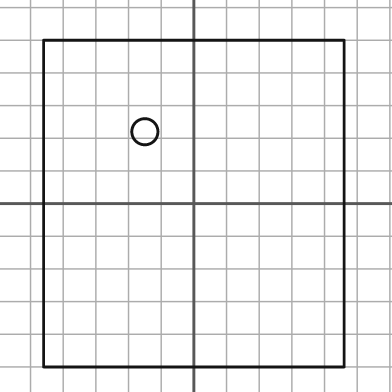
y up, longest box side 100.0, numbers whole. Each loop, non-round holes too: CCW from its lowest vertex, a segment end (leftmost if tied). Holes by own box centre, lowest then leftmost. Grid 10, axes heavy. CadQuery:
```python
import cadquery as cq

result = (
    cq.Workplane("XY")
    .moveTo(-46.0, -50.0)
    .lineTo(46.0, -50.0)
    .lineTo(46.0, 50.0)
    .lineTo(-46.0, 50.0)
    .close()
    .moveTo(-15.0, 22.0)
    .circle(4.0)
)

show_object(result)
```